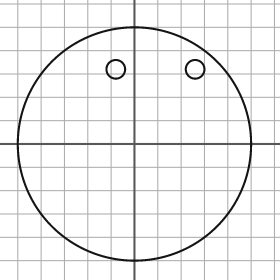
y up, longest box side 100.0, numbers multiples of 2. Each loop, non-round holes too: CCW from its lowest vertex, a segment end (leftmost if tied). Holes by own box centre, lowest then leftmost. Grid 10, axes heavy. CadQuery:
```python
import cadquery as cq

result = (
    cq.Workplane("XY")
    .moveTo(0.0, 0.0)
    .circle(50.0)
    .moveTo(-8.0, 32.0)
    .circle(4.0)
    .moveTo(26.0, 32.0)
    .circle(4.0)
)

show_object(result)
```